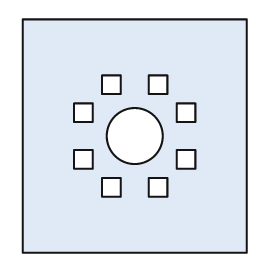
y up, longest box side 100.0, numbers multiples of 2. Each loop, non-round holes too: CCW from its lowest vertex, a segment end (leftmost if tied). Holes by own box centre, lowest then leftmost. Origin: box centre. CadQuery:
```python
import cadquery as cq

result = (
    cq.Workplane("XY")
    .moveTo(-48.0, -50.0)
    .lineTo(48.0, -50.0)
    .lineTo(48.0, 50.0)
    .lineTo(-48.0, 50.0)
    .close()
    .moveTo(-14.0, -26.0)
    .lineTo(-6.0, -26.0)
    .lineTo(-6.0, -18.0)
    .lineTo(-14.0, -18.0)
    .close()
    .moveTo(6.0, -26.0)
    .lineTo(14.0, -26.0)
    .lineTo(14.0, -18.0)
    .lineTo(6.0, -18.0)
    .close()
    .moveTo(-26.0, -14.0)
    .lineTo(-18.0, -14.0)
    .lineTo(-18.0, -6.0)
    .lineTo(-26.0, -6.0)
    .close()
    .moveTo(18.0, -14.0)
    .lineTo(26.0, -14.0)
    .lineTo(26.0, -6.0)
    .lineTo(18.0, -6.0)
    .close()
    .moveTo(0.0, 0.0)
    .circle(12.0)
    .moveTo(-26.0, 6.0)
    .lineTo(-18.0, 6.0)
    .lineTo(-18.0, 14.0)
    .lineTo(-26.0, 14.0)
    .close()
    .moveTo(18.0, 6.0)
    .lineTo(26.0, 6.0)
    .lineTo(26.0, 14.0)
    .lineTo(18.0, 14.0)
    .close()
    .moveTo(-14.0, 18.0)
    .lineTo(-6.0, 18.0)
    .lineTo(-6.0, 26.0)
    .lineTo(-14.0, 26.0)
    .close()
    .moveTo(6.0, 18.0)
    .lineTo(14.0, 18.0)
    .lineTo(14.0, 26.0)
    .lineTo(6.0, 26.0)
    .close()
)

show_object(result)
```